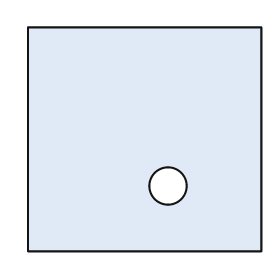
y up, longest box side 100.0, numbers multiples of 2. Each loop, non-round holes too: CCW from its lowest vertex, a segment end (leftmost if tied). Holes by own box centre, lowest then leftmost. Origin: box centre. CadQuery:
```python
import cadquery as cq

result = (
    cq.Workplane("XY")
    .moveTo(-50.0, -48.0)
    .lineTo(50.0, -48.0)
    .lineTo(50.0, 48.0)
    .lineTo(-50.0, 48.0)
    .close()
    .moveTo(10.0, -20.0)
    .circle(8.0)
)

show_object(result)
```